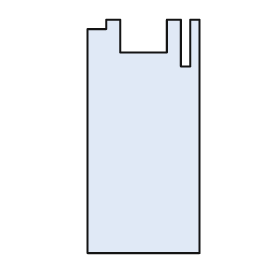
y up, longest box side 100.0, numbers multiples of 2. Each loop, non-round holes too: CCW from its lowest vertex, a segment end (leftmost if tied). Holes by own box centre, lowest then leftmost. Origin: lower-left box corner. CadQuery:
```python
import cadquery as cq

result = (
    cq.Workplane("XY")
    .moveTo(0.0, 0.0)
    .lineTo(48.0, 0.0)
    .lineTo(48.0, 100.0)
    .lineTo(44.0, 100.0)
    .lineTo(44.0, 80.0)
    .lineTo(40.0, 80.0)
    .lineTo(40.0, 100.0)
    .lineTo(34.0, 100.0)
    .lineTo(34.0, 86.0)
    .lineTo(14.0, 86.0)
    .lineTo(14.0, 100.0)
    .lineTo(8.0, 100.0)
    .lineTo(8.0, 96.0)
    .lineTo(0.0, 96.0)
    .close()
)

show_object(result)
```